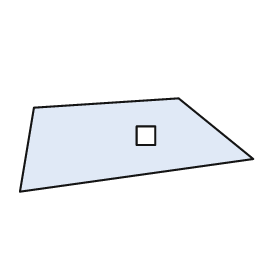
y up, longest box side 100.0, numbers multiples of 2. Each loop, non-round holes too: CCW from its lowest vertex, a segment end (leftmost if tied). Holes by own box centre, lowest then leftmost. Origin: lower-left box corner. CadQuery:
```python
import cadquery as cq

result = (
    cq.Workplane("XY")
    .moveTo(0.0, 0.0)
    .lineTo(100.0, 14.0)
    .lineTo(68.0, 40.0)
    .lineTo(6.0, 36.0)
    .close()
    .moveTo(50.0, 20.0)
    .lineTo(58.0, 20.0)
    .lineTo(58.0, 28.0)
    .lineTo(50.0, 28.0)
    .close()
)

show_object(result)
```